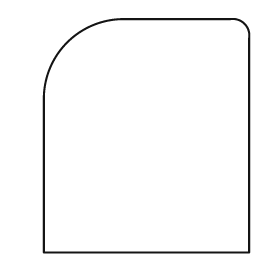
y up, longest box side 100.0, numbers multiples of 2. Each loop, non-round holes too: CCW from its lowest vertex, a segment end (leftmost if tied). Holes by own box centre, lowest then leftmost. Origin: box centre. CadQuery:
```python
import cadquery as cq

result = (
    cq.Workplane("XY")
    .moveTo(-44.0, -50.0)
    .lineTo(44.0, -50.0)
    .lineTo(44.0, 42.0)
    .threePointArc((42.0, 48.0), (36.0, 50.0))
    .lineTo(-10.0, 50.0)
    .threePointArc((-34.0, 40.0), (-44.0, 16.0))
    .close()
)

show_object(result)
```